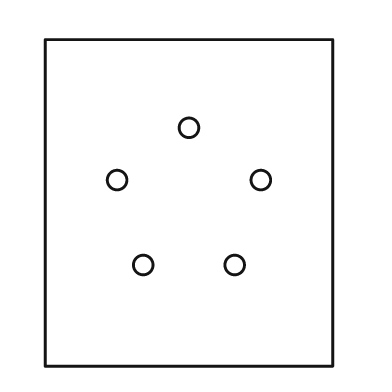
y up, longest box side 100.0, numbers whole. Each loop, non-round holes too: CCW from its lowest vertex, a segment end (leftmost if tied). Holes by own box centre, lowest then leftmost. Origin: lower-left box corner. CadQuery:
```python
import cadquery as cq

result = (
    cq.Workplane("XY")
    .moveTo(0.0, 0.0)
    .lineTo(88.0, 0.0)
    .lineTo(88.0, 100.0)
    .lineTo(0.0, 100.0)
    .close()
    .moveTo(30.0, 31.0)
    .circle(3.0)
    .moveTo(58.0, 31.0)
    .circle(3.0)
    .moveTo(22.0, 57.0)
    .circle(3.0)
    .moveTo(66.0, 57.0)
    .circle(3.0)
    .moveTo(44.0, 73.0)
    .circle(3.0)
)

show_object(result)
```